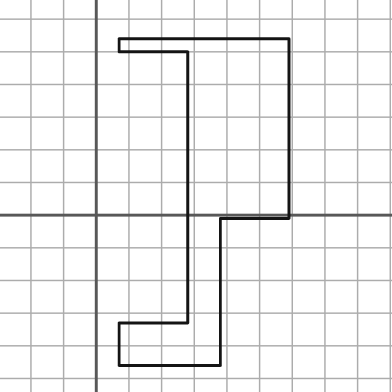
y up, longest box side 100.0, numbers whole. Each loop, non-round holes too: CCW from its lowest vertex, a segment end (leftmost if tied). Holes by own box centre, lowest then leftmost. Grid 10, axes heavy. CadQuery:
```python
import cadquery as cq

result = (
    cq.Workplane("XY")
    .moveTo(7.0, -46.0)
    .lineTo(38.0, -46.0)
    .lineTo(38.0, -1.0)
    .lineTo(59.0, -1.0)
    .lineTo(59.0, 54.0)
    .lineTo(7.0, 54.0)
    .lineTo(7.0, 50.0)
    .lineTo(28.0, 50.0)
    .lineTo(28.0, -33.0)
    .lineTo(7.0, -33.0)
    .close()
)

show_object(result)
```